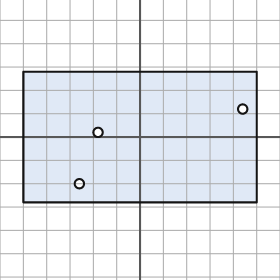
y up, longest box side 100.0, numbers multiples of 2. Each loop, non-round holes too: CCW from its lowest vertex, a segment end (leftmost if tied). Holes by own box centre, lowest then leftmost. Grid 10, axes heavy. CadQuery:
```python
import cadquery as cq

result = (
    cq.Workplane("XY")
    .moveTo(-50.0, -28.0)
    .lineTo(50.0, -28.0)
    .lineTo(50.0, 28.0)
    .lineTo(-50.0, 28.0)
    .close()
    .moveTo(-26.0, -20.0)
    .circle(2.0)
    .moveTo(-18.0, 2.0)
    .circle(2.0)
    .moveTo(44.0, 12.0)
    .circle(2.0)
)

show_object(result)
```